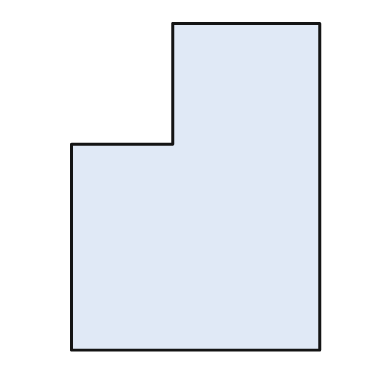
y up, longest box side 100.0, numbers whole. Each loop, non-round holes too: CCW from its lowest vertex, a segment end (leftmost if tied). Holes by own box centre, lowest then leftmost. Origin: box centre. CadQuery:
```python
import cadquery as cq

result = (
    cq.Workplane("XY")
    .moveTo(-38.0, -50.0)
    .lineTo(38.0, -50.0)
    .lineTo(38.0, 50.0)
    .lineTo(-7.0, 50.0)
    .lineTo(-7.0, 13.0)
    .lineTo(-38.0, 13.0)
    .close()
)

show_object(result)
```